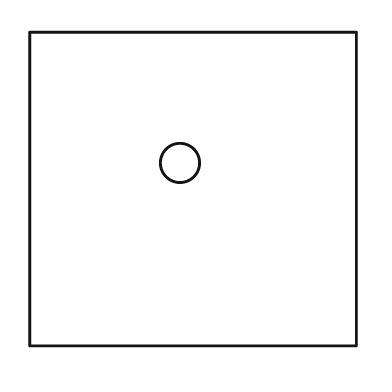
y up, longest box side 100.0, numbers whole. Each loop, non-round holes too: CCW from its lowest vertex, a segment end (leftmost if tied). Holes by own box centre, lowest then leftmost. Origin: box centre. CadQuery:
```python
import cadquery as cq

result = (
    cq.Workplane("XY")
    .moveTo(-50.0, -48.0)
    .lineTo(50.0, -48.0)
    .lineTo(50.0, 48.0)
    .lineTo(-50.0, 48.0)
    .close()
    .moveTo(-4.0, 8.0)
    .circle(6.0)
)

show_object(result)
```